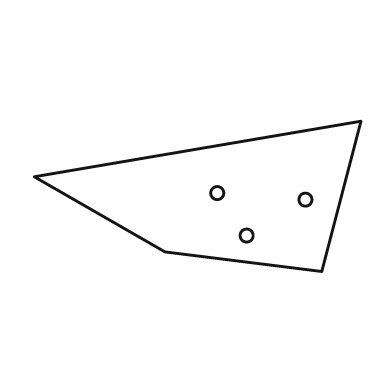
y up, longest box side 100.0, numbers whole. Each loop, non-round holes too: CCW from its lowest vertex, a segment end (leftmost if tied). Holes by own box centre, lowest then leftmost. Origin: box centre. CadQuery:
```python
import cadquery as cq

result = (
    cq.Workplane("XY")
    .moveTo(38.0, -23.0)
    .lineTo(50.0, 23.0)
    .lineTo(-50.0, 6.0)
    .lineTo(-10.0, -17.0)
    .close()
    .moveTo(15.0, -12.0)
    .circle(2.0)
    .moveTo(33.0, -1.0)
    .circle(2.0)
    .moveTo(6.0, 1.0)
    .circle(2.0)
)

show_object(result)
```